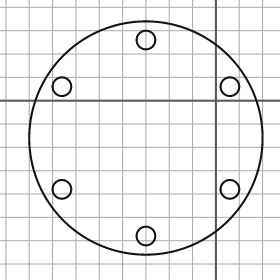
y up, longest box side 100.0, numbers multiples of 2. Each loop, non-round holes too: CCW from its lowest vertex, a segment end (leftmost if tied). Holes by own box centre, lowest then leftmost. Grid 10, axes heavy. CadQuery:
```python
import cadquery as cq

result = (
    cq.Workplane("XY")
    .moveTo(-30.0, -16.0)
    .circle(50.0)
    .moveTo(-30.0, -58.0)
    .circle(4.0)
    .moveTo(-66.0, -38.0)
    .circle(4.0)
    .moveTo(6.0, -38.0)
    .circle(4.0)
    .moveTo(-66.0, 6.0)
    .circle(4.0)
    .moveTo(6.0, 6.0)
    .circle(4.0)
    .moveTo(-30.0, 26.0)
    .circle(4.0)
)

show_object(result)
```